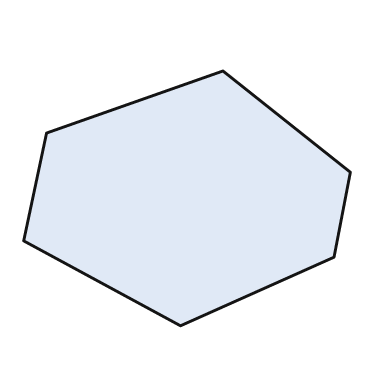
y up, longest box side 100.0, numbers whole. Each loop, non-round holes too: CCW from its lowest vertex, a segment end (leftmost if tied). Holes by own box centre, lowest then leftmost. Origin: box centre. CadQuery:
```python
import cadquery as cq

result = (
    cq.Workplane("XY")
    .moveTo(-2.0, -39.0)
    .lineTo(45.0, -18.0)
    .lineTo(50.0, 8.0)
    .lineTo(11.0, 39.0)
    .lineTo(-43.0, 20.0)
    .lineTo(-50.0, -13.0)
    .close()
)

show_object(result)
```